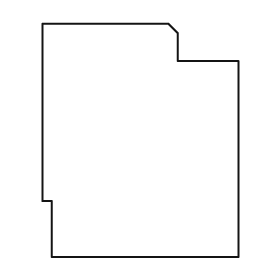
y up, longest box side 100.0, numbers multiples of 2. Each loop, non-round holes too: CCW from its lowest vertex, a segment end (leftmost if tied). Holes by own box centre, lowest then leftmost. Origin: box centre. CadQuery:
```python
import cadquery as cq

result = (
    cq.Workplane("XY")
    .moveTo(-38.0, -50.0)
    .lineTo(42.0, -50.0)
    .lineTo(42.0, 34.0)
    .lineTo(16.0, 34.0)
    .lineTo(16.0, 46.0)
    .lineTo(12.0, 50.0)
    .lineTo(-42.0, 50.0)
    .lineTo(-42.0, -26.0)
    .lineTo(-38.0, -26.0)
    .close()
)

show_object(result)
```